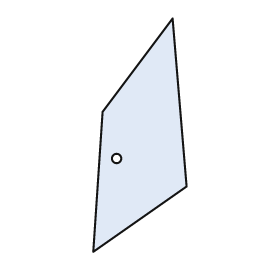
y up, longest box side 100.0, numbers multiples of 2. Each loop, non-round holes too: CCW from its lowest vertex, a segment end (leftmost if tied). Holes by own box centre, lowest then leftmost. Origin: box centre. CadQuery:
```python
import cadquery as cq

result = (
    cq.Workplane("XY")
    .moveTo(-20.0, -50.0)
    .lineTo(20.0, -22.0)
    .lineTo(14.0, 50.0)
    .lineTo(-16.0, 10.0)
    .close()
    .moveTo(-10.0, -10.0)
    .circle(2.0)
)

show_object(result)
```